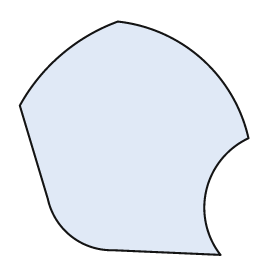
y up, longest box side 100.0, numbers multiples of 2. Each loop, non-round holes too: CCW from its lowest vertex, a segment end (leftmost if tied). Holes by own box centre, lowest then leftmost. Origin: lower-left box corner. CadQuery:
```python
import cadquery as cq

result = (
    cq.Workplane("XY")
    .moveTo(86.0, 0.0)
    .threePointArc((80.0, 28.0), (98.0, 50.0))
    .threePointArc((78.0, 84.0), (42.0, 100.0))
    .threePointArc((18.0, 86.0), (0.0, 64.0))
    .lineTo(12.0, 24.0)
    .threePointArc((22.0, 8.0), (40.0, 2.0))
    .close()
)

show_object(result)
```